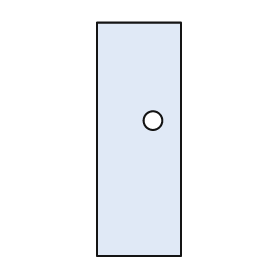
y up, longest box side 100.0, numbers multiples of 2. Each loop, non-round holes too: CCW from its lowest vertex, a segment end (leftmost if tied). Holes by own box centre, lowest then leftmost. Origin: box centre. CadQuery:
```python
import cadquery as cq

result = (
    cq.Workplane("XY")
    .moveTo(-18.0, -50.0)
    .lineTo(18.0, -50.0)
    .lineTo(18.0, 50.0)
    .lineTo(-18.0, 50.0)
    .close()
    .moveTo(6.0, 8.0)
    .circle(4.0)
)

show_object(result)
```